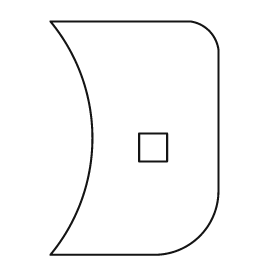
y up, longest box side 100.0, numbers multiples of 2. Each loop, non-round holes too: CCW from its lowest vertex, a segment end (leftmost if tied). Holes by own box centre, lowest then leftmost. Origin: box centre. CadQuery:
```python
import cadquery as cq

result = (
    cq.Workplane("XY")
    .moveTo(-36.0, -50.0)
    .lineTo(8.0, -50.0)
    .threePointArc((28.0, -42.0), (36.0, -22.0))
    .lineTo(36.0, 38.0)
    .threePointArc((32.0, 46.0), (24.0, 50.0))
    .lineTo(-36.0, 50.0)
    .threePointArc((-18.0, 0.0), (-36.0, -50.0))
    .close()
    .moveTo(2.0, -10.0)
    .lineTo(14.0, -10.0)
    .lineTo(14.0, 2.0)
    .lineTo(2.0, 2.0)
    .close()
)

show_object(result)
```